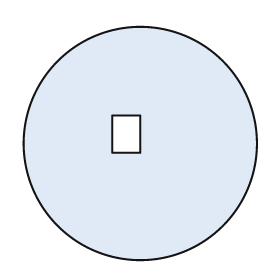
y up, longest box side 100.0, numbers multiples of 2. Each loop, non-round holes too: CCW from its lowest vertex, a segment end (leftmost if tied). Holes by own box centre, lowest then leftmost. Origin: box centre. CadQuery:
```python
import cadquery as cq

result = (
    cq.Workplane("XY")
    .moveTo(0.0, 0.0)
    .circle(50.0)
    .moveTo(-12.0, -4.0)
    .lineTo(0.0, -4.0)
    .lineTo(0.0, 12.0)
    .lineTo(-12.0, 12.0)
    .close()
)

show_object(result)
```